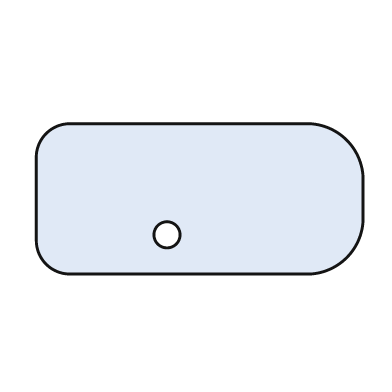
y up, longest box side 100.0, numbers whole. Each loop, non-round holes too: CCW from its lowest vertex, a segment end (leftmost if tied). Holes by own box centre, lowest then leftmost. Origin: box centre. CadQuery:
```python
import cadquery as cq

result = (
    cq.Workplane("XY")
    .moveTo(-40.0, -23.0)
    .lineTo(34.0, -23.0)
    .threePointArc((45.0, -18.0), (50.0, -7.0))
    .lineTo(50.0, 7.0)
    .threePointArc((45.0, 18.0), (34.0, 23.0))
    .lineTo(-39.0, 23.0)
    .threePointArc((-47.0, 20.0), (-50.0, 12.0))
    .lineTo(-50.0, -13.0)
    .threePointArc((-47.0, -20.0), (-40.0, -23.0))
    .close()
    .moveTo(-10.0, -11.0)
    .circle(4.0)
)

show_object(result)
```